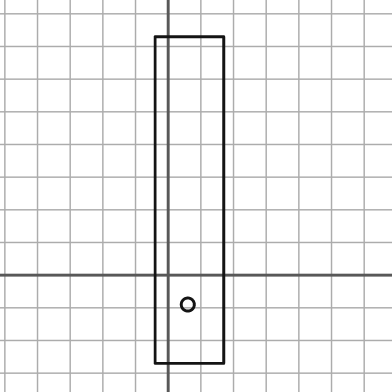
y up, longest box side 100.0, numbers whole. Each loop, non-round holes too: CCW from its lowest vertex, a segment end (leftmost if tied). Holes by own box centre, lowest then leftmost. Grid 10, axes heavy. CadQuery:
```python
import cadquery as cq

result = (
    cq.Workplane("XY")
    .moveTo(-4.0, -27.0)
    .lineTo(17.0, -27.0)
    .lineTo(17.0, 73.0)
    .lineTo(-4.0, 73.0)
    .close()
    .moveTo(6.0, -9.0)
    .circle(2.0)
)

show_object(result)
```